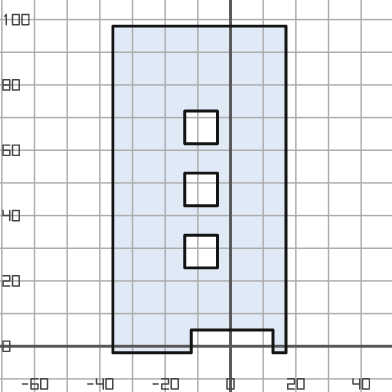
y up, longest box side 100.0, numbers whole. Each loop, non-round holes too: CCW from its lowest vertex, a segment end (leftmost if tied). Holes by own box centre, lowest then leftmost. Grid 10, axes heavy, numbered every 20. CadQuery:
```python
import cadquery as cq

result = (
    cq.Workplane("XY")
    .moveTo(-36.0, -2.0)
    .lineTo(-12.0, -2.0)
    .lineTo(-12.0, 5.0)
    .lineTo(13.0, 5.0)
    .lineTo(13.0, -2.0)
    .lineTo(17.0, -2.0)
    .lineTo(17.0, 98.0)
    .lineTo(-36.0, 98.0)
    .close()
    .moveTo(-14.0, 24.0)
    .lineTo(-4.0, 24.0)
    .lineTo(-4.0, 34.0)
    .lineTo(-14.0, 34.0)
    .close()
    .moveTo(-14.0, 43.0)
    .lineTo(-4.0, 43.0)
    .lineTo(-4.0, 53.0)
    .lineTo(-14.0, 53.0)
    .close()
    .moveTo(-14.0, 62.0)
    .lineTo(-4.0, 62.0)
    .lineTo(-4.0, 72.0)
    .lineTo(-14.0, 72.0)
    .close()
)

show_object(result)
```